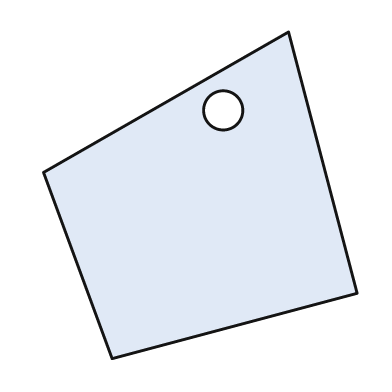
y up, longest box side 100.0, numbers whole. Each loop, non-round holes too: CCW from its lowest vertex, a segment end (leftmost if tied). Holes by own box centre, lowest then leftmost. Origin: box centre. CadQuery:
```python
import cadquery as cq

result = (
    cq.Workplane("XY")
    .moveTo(-27.0, -50.0)
    .lineTo(48.0, -30.0)
    .lineTo(27.0, 50.0)
    .lineTo(-48.0, 7.0)
    .close()
    .moveTo(7.0, 26.0)
    .circle(6.0)
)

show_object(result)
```